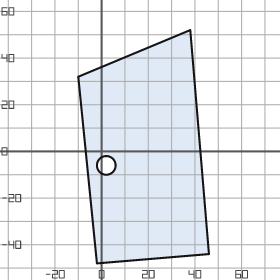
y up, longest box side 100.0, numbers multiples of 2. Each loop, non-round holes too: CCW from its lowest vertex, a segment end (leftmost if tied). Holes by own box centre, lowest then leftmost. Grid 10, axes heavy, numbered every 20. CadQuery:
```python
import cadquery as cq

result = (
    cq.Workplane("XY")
    .moveTo(-2.0, -48.0)
    .lineTo(46.0, -44.0)
    .lineTo(38.0, 52.0)
    .lineTo(-10.0, 32.0)
    .close()
    .moveTo(2.0, -6.0)
    .circle(4.0)
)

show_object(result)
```